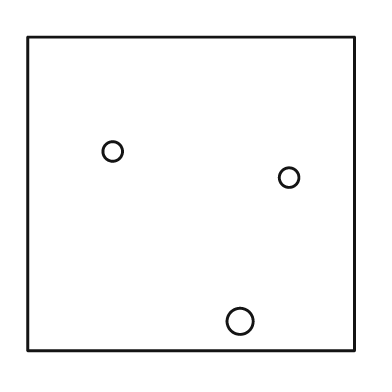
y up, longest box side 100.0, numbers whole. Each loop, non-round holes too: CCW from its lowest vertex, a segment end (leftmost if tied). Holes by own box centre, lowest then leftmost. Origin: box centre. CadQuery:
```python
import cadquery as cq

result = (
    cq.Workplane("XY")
    .moveTo(-50.0, -48.0)
    .lineTo(50.0, -48.0)
    .lineTo(50.0, 48.0)
    .lineTo(-50.0, 48.0)
    .close()
    .moveTo(15.0, -39.0)
    .circle(4.0)
    .moveTo(30.0, 5.0)
    .circle(3.0)
    .moveTo(-24.0, 13.0)
    .circle(3.0)
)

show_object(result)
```